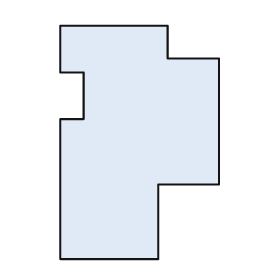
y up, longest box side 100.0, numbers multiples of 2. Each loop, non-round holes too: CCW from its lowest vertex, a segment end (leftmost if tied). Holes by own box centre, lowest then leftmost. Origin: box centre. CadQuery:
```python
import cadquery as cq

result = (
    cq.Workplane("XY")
    .moveTo(-34.0, -50.0)
    .lineTo(8.0, -50.0)
    .lineTo(8.0, -18.0)
    .lineTo(34.0, -18.0)
    .lineTo(34.0, 36.0)
    .lineTo(12.0, 36.0)
    .lineTo(12.0, 50.0)
    .lineTo(-34.0, 50.0)
    .lineTo(-34.0, 30.0)
    .lineTo(-24.0, 30.0)
    .lineTo(-24.0, 10.0)
    .lineTo(-34.0, 10.0)
    .close()
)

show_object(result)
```